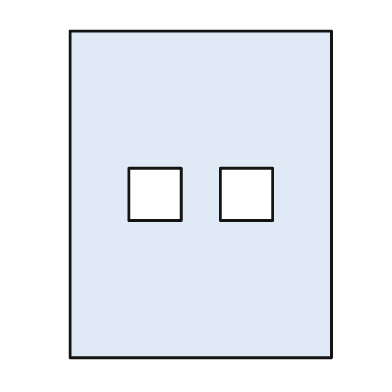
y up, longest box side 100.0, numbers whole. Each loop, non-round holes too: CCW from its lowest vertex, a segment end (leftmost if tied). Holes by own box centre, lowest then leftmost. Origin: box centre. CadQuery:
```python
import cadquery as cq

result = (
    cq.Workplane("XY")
    .moveTo(-40.0, -50.0)
    .lineTo(40.0, -50.0)
    .lineTo(40.0, 50.0)
    .lineTo(-40.0, 50.0)
    .close()
    .moveTo(-22.0, -8.0)
    .lineTo(-6.0, -8.0)
    .lineTo(-6.0, 8.0)
    .lineTo(-22.0, 8.0)
    .close()
    .moveTo(6.0, -8.0)
    .lineTo(22.0, -8.0)
    .lineTo(22.0, 8.0)
    .lineTo(6.0, 8.0)
    .close()
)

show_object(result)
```